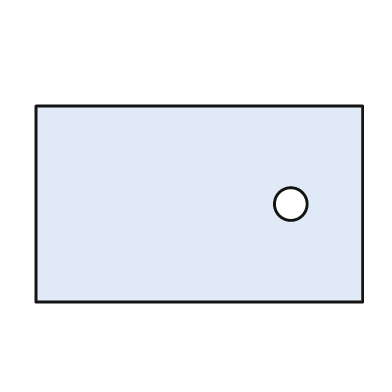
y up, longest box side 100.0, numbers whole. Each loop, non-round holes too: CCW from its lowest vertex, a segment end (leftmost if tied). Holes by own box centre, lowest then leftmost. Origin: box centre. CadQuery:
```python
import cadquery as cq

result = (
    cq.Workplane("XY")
    .moveTo(-50.0, -30.0)
    .lineTo(50.0, -30.0)
    .lineTo(50.0, 30.0)
    .lineTo(-50.0, 30.0)
    .close()
    .moveTo(28.0, 0.0)
    .circle(5.0)
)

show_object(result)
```